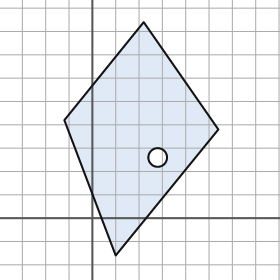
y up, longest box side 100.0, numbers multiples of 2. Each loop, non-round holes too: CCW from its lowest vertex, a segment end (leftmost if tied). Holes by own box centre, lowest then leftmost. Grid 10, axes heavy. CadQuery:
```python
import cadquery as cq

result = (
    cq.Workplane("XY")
    .moveTo(10.0, -16.0)
    .lineTo(54.0, 38.0)
    .lineTo(22.0, 84.0)
    .lineTo(-12.0, 42.0)
    .close()
    .moveTo(28.0, 26.0)
    .circle(4.0)
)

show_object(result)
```